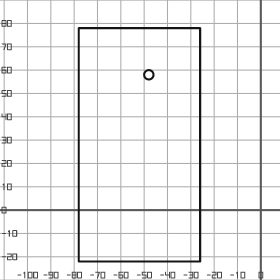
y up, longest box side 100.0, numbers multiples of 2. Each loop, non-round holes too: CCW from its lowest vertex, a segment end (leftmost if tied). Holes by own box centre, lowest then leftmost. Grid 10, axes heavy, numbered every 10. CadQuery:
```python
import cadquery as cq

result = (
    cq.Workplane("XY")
    .moveTo(-78.0, -22.0)
    .lineTo(-26.0, -22.0)
    .lineTo(-26.0, 78.0)
    .lineTo(-78.0, 78.0)
    .close()
    .moveTo(-48.0, 58.0)
    .circle(2.0)
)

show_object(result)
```